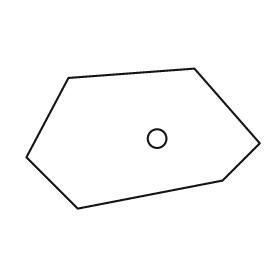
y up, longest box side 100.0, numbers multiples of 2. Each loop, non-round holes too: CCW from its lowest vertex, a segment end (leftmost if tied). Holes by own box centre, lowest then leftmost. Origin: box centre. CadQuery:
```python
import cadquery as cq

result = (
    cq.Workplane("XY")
    .moveTo(-28.0, -30.0)
    .lineTo(34.0, -18.0)
    .lineTo(50.0, -2.0)
    .lineTo(22.0, 30.0)
    .lineTo(-32.0, 26.0)
    .lineTo(-50.0, -8.0)
    .close()
    .moveTo(6.0, 0.0)
    .circle(4.0)
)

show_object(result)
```